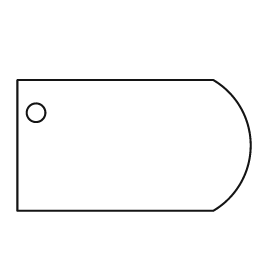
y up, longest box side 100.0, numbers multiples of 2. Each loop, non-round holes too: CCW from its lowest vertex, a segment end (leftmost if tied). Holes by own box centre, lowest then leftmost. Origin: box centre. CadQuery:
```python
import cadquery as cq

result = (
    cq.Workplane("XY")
    .moveTo(-50.0, -28.0)
    .lineTo(34.0, -28.0)
    .threePointArc((50.0, 0.0), (34.0, 28.0))
    .lineTo(-50.0, 28.0)
    .close()
    .moveTo(-42.0, 14.0)
    .circle(4.0)
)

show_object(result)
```